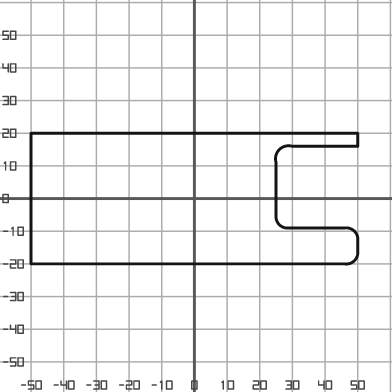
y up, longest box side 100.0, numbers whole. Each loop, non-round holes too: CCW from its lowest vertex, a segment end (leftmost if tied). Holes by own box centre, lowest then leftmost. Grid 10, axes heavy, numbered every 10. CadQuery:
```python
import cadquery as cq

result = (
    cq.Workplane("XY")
    .moveTo(-50.0, -20.0)
    .lineTo(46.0, -20.0)
    .threePointArc((49.0, -19.0), (50.0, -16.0))
    .lineTo(50.0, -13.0)
    .threePointArc((49.0, -10.0), (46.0, -9.0))
    .lineTo(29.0, -9.0)
    .threePointArc((26.0, -8.0), (25.0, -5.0))
    .lineTo(25.0, 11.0)
    .threePointArc((26.0, 15.0), (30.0, 16.0))
    .lineTo(50.0, 16.0)
    .lineTo(50.0, 20.0)
    .lineTo(-50.0, 20.0)
    .close()
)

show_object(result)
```